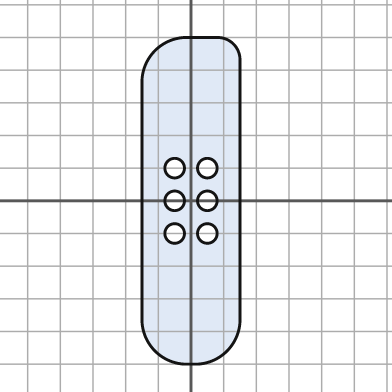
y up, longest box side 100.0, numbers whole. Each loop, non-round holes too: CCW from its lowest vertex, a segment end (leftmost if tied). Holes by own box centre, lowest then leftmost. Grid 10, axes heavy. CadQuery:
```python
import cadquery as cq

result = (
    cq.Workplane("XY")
    .moveTo(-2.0, -50.0)
    .lineTo(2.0, -50.0)
    .threePointArc((11.0, -46.0), (15.0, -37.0))
    .lineTo(15.0, 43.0)
    .threePointArc((13.0, 48.0), (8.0, 50.0))
    .lineTo(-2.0, 50.0)
    .threePointArc((-11.0, 46.0), (-15.0, 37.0))
    .lineTo(-15.0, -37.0)
    .threePointArc((-11.0, -46.0), (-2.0, -50.0))
    .close()
    .moveTo(-5.0, -10.0)
    .circle(3.0)
    .moveTo(5.0, -10.0)
    .circle(3.0)
    .moveTo(-5.0, 0.0)
    .circle(3.0)
    .moveTo(5.0, 0.0)
    .circle(3.0)
    .moveTo(-5.0, 10.0)
    .circle(3.0)
    .moveTo(5.0, 10.0)
    .circle(3.0)
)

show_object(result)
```